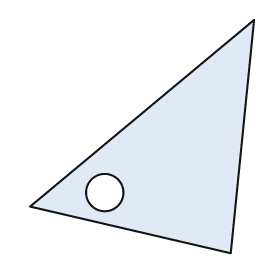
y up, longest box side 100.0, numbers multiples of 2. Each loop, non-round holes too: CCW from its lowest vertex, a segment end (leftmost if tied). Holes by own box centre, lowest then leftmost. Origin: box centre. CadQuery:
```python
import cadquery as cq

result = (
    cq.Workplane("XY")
    .moveTo(38.0, -50.0)
    .lineTo(48.0, 50.0)
    .lineTo(-48.0, -30.0)
    .close()
    .moveTo(-16.0, -24.0)
    .circle(8.0)
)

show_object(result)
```